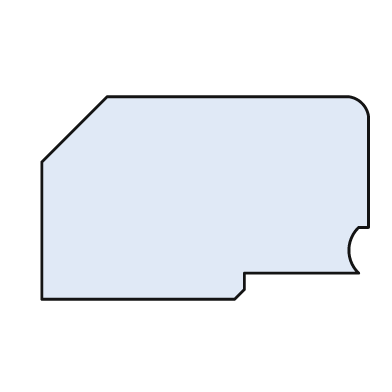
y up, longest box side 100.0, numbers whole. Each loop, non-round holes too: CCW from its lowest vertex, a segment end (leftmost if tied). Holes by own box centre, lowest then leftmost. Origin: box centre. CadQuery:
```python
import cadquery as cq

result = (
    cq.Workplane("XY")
    .moveTo(-50.0, -31.0)
    .lineTo(9.0, -31.0)
    .lineTo(12.0, -28.0)
    .lineTo(12.0, -23.0)
    .lineTo(47.0, -23.0)
    .threePointArc((44.0, -16.0), (47.0, -9.0))
    .lineTo(50.0, -9.0)
    .lineTo(50.0, 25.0)
    .threePointArc((48.0, 29.0), (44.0, 31.0))
    .lineTo(-30.0, 31.0)
    .lineTo(-50.0, 11.0)
    .close()
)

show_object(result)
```